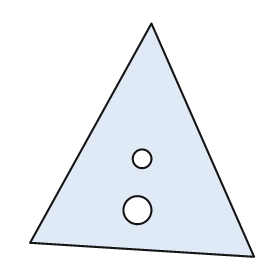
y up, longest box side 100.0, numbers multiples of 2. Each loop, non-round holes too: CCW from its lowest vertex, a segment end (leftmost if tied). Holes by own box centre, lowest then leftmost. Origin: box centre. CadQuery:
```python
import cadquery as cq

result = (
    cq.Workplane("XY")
    .moveTo(48.0, -50.0)
    .lineTo(4.0, 50.0)
    .lineTo(-48.0, -44.0)
    .close()
    .moveTo(-2.0, -30.0)
    .circle(6.0)
    .moveTo(0.0, -8.0)
    .circle(4.0)
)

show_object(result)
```